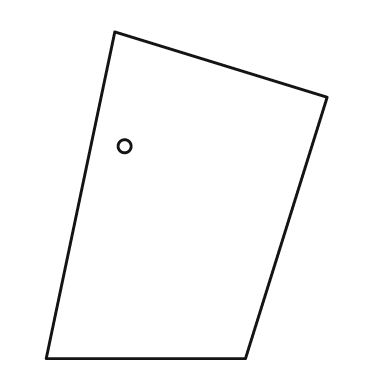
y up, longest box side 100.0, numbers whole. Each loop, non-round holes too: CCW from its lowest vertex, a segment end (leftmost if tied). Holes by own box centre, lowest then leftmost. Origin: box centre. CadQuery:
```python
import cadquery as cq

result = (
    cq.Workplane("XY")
    .moveTo(-43.0, -50.0)
    .lineTo(18.0, -50.0)
    .lineTo(43.0, 30.0)
    .lineTo(-22.0, 50.0)
    .close()
    .moveTo(-19.0, 15.0)
    .circle(2.0)
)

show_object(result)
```